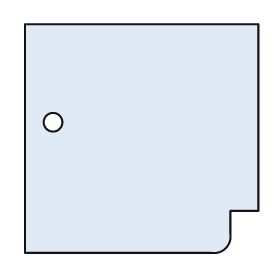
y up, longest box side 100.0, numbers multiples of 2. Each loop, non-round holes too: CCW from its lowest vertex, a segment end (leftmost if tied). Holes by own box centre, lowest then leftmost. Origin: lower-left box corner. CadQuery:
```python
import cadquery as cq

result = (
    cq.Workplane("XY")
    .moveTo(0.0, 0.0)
    .lineTo(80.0, 0.0)
    .threePointArc((86.0, 2.0), (88.0, 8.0))
    .lineTo(88.0, 18.0)
    .lineTo(100.0, 18.0)
    .lineTo(100.0, 98.0)
    .lineTo(0.0, 98.0)
    .close()
    .moveTo(12.0, 56.0)
    .circle(4.0)
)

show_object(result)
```